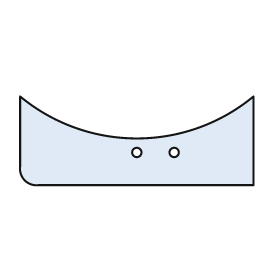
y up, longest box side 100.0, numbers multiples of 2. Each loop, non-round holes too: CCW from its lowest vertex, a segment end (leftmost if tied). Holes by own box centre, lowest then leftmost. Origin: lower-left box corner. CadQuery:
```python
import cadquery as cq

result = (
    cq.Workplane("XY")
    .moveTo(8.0, 0.0)
    .lineTo(100.0, 0.0)
    .lineTo(100.0, 38.0)
    .threePointArc((50.0, 20.0), (0.0, 38.0))
    .lineTo(0.0, 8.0)
    .threePointArc((2.0, 2.0), (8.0, 0.0))
    .close()
    .moveTo(50.0, 14.0)
    .circle(2.0)
    .moveTo(66.0, 14.0)
    .circle(2.0)
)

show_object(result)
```